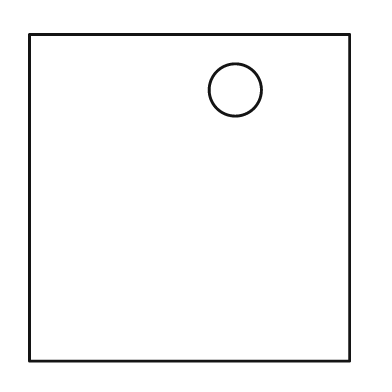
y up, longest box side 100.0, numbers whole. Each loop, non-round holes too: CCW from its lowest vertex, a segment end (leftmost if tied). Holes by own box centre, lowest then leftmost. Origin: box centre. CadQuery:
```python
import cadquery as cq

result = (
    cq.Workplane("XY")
    .moveTo(-49.0, -50.0)
    .lineTo(49.0, -50.0)
    .lineTo(49.0, 50.0)
    .lineTo(-49.0, 50.0)
    .close()
    .moveTo(14.0, 33.0)
    .circle(8.0)
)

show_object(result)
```